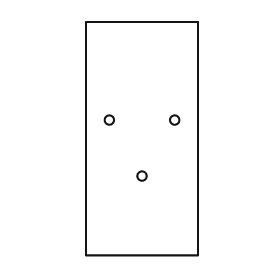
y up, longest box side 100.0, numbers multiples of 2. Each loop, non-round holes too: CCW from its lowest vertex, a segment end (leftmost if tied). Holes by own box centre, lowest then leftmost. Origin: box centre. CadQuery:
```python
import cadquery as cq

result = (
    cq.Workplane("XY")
    .moveTo(-24.0, -50.0)
    .lineTo(24.0, -50.0)
    .lineTo(24.0, 50.0)
    .lineTo(-24.0, 50.0)
    .close()
    .moveTo(0.0, -16.0)
    .circle(2.0)
    .moveTo(-14.0, 8.0)
    .circle(2.0)
    .moveTo(14.0, 8.0)
    .circle(2.0)
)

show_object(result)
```